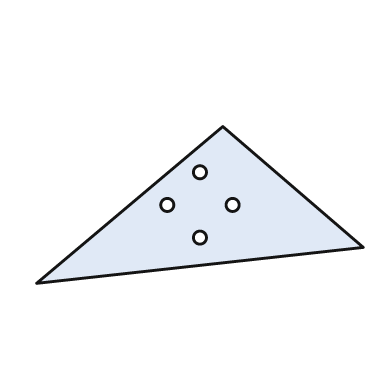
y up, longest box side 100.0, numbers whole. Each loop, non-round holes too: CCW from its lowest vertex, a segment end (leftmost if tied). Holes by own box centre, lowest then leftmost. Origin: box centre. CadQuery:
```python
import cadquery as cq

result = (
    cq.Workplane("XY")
    .moveTo(-50.0, -24.0)
    .lineTo(50.0, -13.0)
    .lineTo(7.0, 24.0)
    .close()
    .moveTo(0.0, -10.0)
    .circle(2.0)
    .moveTo(-10.0, 0.0)
    .circle(2.0)
    .moveTo(10.0, 0.0)
    .circle(2.0)
    .moveTo(0.0, 10.0)
    .circle(2.0)
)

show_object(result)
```